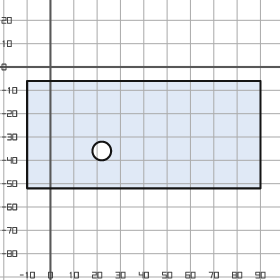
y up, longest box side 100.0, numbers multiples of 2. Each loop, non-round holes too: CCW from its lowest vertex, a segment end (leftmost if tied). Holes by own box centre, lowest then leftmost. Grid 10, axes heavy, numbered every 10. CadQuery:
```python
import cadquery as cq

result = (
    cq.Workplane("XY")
    .moveTo(-10.0, -52.0)
    .lineTo(90.0, -52.0)
    .lineTo(90.0, -6.0)
    .lineTo(-10.0, -6.0)
    .close()
    .moveTo(22.0, -36.0)
    .circle(4.0)
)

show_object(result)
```